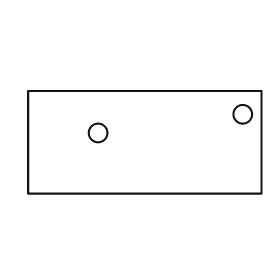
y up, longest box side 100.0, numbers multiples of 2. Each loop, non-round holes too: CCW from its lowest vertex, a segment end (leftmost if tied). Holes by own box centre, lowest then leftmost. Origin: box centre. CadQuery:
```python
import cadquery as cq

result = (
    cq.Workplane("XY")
    .moveTo(-50.0, -22.0)
    .lineTo(50.0, -22.0)
    .lineTo(50.0, 22.0)
    .lineTo(-50.0, 22.0)
    .close()
    .moveTo(-20.0, 4.0)
    .circle(4.0)
    .moveTo(42.0, 12.0)
    .circle(4.0)
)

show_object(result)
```